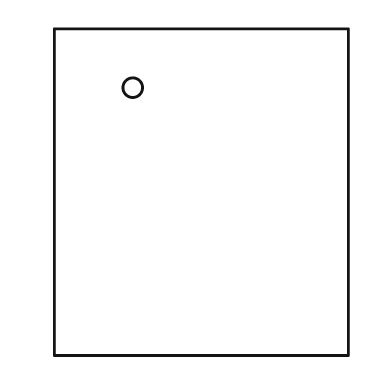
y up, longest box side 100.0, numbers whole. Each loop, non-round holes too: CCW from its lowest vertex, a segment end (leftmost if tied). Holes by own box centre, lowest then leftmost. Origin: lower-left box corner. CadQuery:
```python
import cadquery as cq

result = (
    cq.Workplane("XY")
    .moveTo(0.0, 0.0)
    .lineTo(90.0, 0.0)
    .lineTo(90.0, 100.0)
    .lineTo(0.0, 100.0)
    .close()
    .moveTo(24.0, 82.0)
    .circle(3.0)
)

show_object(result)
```